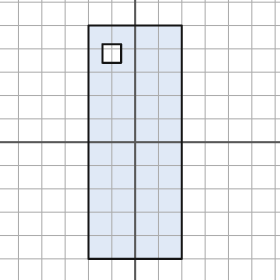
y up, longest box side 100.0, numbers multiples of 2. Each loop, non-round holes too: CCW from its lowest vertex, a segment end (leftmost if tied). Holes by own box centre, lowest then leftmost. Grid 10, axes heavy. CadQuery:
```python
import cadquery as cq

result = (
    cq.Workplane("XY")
    .moveTo(-20.0, -50.0)
    .lineTo(20.0, -50.0)
    .lineTo(20.0, 50.0)
    .lineTo(-20.0, 50.0)
    .close()
    .moveTo(-14.0, 34.0)
    .lineTo(-6.0, 34.0)
    .lineTo(-6.0, 42.0)
    .lineTo(-14.0, 42.0)
    .close()
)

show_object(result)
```